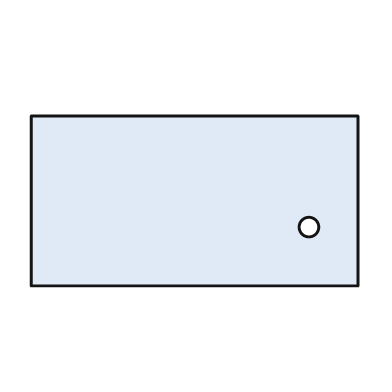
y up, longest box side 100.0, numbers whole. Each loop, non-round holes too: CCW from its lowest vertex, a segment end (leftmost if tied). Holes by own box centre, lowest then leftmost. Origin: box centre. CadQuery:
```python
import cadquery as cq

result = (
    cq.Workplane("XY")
    .moveTo(-50.0, -26.0)
    .lineTo(50.0, -26.0)
    .lineTo(50.0, 26.0)
    .lineTo(-50.0, 26.0)
    .close()
    .moveTo(35.0, -8.0)
    .circle(3.0)
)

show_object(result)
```